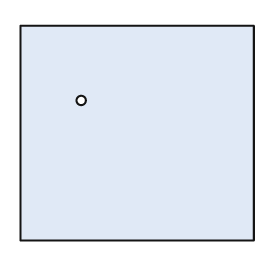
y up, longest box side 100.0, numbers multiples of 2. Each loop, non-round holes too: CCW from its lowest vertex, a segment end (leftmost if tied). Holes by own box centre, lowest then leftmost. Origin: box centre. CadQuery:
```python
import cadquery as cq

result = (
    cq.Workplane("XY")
    .moveTo(-50.0, -46.0)
    .lineTo(50.0, -46.0)
    .lineTo(50.0, 46.0)
    .lineTo(-50.0, 46.0)
    .close()
    .moveTo(-24.0, 14.0)
    .circle(2.0)
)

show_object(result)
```